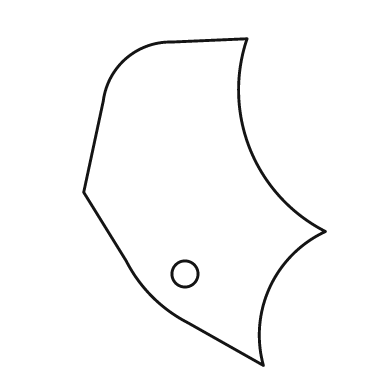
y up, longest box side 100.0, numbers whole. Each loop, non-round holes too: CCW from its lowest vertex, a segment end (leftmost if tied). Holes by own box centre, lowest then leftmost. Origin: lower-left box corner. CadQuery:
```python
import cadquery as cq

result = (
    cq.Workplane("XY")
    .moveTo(55.0, 0.0)
    .threePointArc((57.0, 24.0), (74.0, 41.0))
    .threePointArc((51.0, 66.0), (50.0, 100.0))
    .lineTo(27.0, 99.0)
    .threePointArc((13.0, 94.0), (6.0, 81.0))
    .lineTo(0.0, 53.0)
    .lineTo(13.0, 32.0)
    .threePointArc((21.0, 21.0), (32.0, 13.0))
    .close()
    .moveTo(31.0, 28.0)
    .circle(4.0)
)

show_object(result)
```